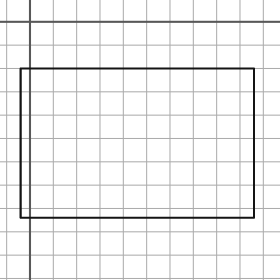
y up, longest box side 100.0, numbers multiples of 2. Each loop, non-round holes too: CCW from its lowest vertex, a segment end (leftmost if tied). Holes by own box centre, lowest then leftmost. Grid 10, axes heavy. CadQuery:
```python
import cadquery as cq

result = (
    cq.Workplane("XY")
    .moveTo(-4.0, -84.0)
    .lineTo(96.0, -84.0)
    .lineTo(96.0, -20.0)
    .lineTo(-4.0, -20.0)
    .close()
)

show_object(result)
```